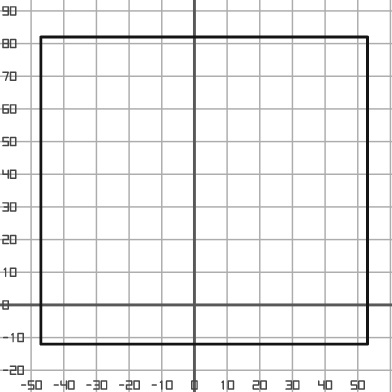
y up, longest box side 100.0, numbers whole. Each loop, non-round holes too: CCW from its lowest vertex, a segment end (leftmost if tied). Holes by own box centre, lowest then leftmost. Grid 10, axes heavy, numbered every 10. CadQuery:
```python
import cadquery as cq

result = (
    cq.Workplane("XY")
    .moveTo(-47.0, -12.0)
    .lineTo(53.0, -12.0)
    .lineTo(53.0, 82.0)
    .lineTo(-47.0, 82.0)
    .close()
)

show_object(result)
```